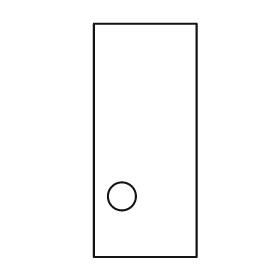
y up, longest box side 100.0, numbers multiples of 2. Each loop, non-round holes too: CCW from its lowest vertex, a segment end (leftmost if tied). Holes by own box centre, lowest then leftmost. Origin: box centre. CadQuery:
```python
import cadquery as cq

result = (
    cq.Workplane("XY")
    .moveTo(-22.0, -50.0)
    .lineTo(22.0, -50.0)
    .lineTo(22.0, 50.0)
    .lineTo(-22.0, 50.0)
    .close()
    .moveTo(-10.0, -24.0)
    .circle(6.0)
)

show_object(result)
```